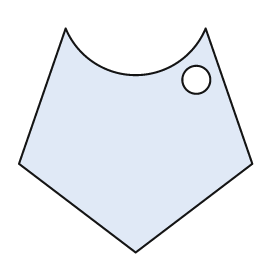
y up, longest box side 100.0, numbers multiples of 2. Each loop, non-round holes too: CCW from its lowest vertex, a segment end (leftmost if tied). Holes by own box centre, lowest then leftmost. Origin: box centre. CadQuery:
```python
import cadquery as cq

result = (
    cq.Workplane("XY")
    .moveTo(0.0, -48.0)
    .lineTo(50.0, -10.0)
    .lineTo(30.0, 48.0)
    .threePointArc((0.0, 28.0), (-30.0, 48.0))
    .lineTo(-50.0, -10.0)
    .close()
    .moveTo(26.0, 26.0)
    .circle(6.0)
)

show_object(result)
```